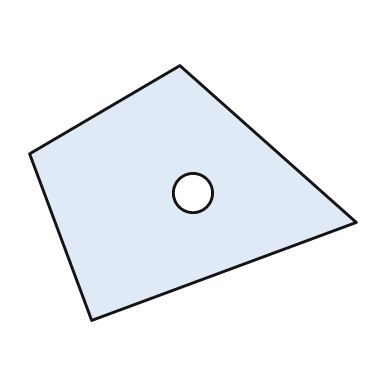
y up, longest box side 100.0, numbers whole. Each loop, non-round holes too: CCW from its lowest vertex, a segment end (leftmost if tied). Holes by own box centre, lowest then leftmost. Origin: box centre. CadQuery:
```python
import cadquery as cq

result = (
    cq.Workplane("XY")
    .moveTo(-31.0, -39.0)
    .lineTo(50.0, -9.0)
    .lineTo(-4.0, 39.0)
    .lineTo(-50.0, 12.0)
    .close()
    .moveTo(0.0, 0.0)
    .circle(6.0)
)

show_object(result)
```